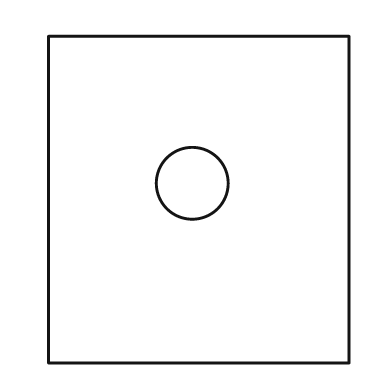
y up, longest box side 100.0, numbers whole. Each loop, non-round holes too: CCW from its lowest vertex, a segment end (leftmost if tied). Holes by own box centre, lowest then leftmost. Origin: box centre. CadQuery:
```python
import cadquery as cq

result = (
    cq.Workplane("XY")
    .moveTo(-46.0, -50.0)
    .lineTo(46.0, -50.0)
    .lineTo(46.0, 50.0)
    .lineTo(-46.0, 50.0)
    .close()
    .moveTo(-2.0, 5.0)
    .circle(11.0)
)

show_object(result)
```